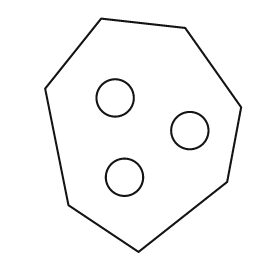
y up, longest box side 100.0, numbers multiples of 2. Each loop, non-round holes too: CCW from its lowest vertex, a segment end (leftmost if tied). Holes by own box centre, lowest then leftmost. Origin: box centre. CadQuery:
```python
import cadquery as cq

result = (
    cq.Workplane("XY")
    .moveTo(-2.0, -50.0)
    .lineTo(36.0, -20.0)
    .lineTo(42.0, 12.0)
    .lineTo(18.0, 46.0)
    .lineTo(-18.0, 50.0)
    .lineTo(-42.0, 20.0)
    .lineTo(-32.0, -30.0)
    .close()
    .moveTo(-8.0, -18.0)
    .circle(8.0)
    .moveTo(20.0, 2.0)
    .circle(8.0)
    .moveTo(-12.0, 16.0)
    .circle(8.0)
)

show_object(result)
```